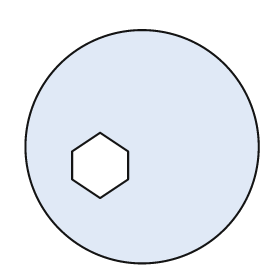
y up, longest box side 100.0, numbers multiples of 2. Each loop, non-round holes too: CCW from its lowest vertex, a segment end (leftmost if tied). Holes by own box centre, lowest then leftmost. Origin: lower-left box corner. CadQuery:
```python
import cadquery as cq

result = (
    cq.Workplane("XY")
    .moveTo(50.0, 50.0)
    .circle(50.0)
    .moveTo(32.0, 28.0)
    .lineTo(44.0, 36.0)
    .lineTo(44.0, 48.0)
    .lineTo(32.0, 56.0)
    .lineTo(20.0, 48.0)
    .lineTo(20.0, 36.0)
    .close()
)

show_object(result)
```